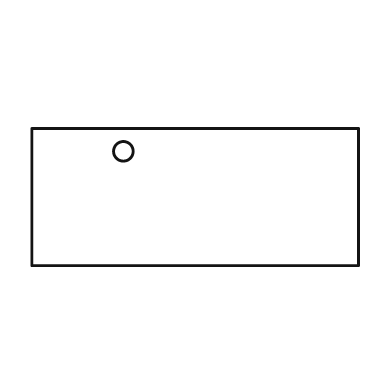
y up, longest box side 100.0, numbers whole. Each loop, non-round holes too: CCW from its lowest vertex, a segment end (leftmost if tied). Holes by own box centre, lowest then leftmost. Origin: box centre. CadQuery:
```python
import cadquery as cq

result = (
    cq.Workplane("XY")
    .moveTo(-50.0, -21.0)
    .lineTo(50.0, -21.0)
    .lineTo(50.0, 21.0)
    .lineTo(-50.0, 21.0)
    .close()
    .moveTo(-22.0, 14.0)
    .circle(3.0)
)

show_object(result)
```